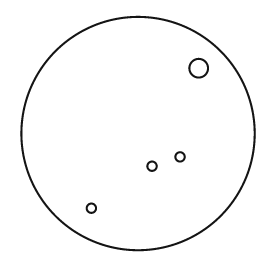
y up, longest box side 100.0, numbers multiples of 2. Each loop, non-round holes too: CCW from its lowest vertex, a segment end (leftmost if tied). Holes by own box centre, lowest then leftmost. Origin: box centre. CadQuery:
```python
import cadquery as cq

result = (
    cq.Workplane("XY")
    .moveTo(0.0, 0.0)
    .circle(50.0)
    .moveTo(-20.0, -32.0)
    .circle(2.0)
    .moveTo(6.0, -14.0)
    .circle(2.0)
    .moveTo(18.0, -10.0)
    .circle(2.0)
    .moveTo(26.0, 28.0)
    .circle(4.0)
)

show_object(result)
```